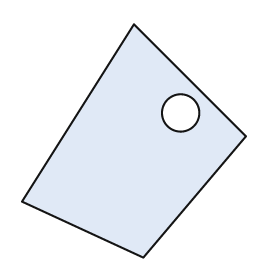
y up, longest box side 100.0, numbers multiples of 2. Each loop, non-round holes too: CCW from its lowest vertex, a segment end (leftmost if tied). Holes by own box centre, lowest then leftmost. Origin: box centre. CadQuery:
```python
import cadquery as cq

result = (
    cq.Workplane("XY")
    .moveTo(4.0, -50.0)
    .lineTo(48.0, 2.0)
    .lineTo(0.0, 50.0)
    .lineTo(-48.0, -26.0)
    .close()
    .moveTo(20.0, 12.0)
    .circle(8.0)
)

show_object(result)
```